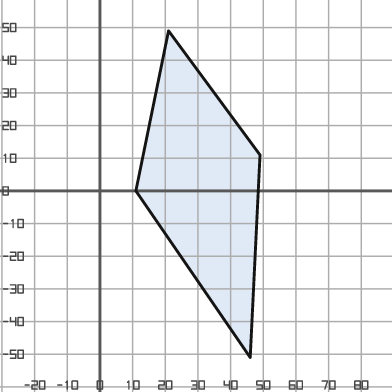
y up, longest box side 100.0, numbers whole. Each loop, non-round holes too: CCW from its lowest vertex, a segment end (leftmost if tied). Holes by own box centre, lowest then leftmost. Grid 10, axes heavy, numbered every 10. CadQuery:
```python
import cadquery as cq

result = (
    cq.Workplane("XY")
    .moveTo(46.0, -51.0)
    .lineTo(49.0, 11.0)
    .lineTo(21.0, 49.0)
    .lineTo(11.0, 0.0)
    .close()
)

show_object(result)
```